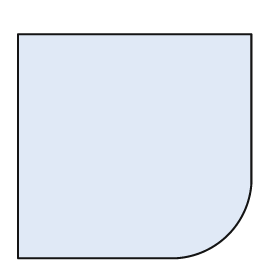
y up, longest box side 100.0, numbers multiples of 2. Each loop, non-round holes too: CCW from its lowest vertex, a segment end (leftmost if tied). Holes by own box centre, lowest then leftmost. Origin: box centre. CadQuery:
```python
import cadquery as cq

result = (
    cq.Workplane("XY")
    .moveTo(-50.0, -48.0)
    .lineTo(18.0, -48.0)
    .threePointArc((40.0, -38.0), (50.0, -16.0))
    .lineTo(50.0, 48.0)
    .lineTo(-50.0, 48.0)
    .close()
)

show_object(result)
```